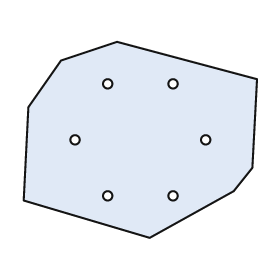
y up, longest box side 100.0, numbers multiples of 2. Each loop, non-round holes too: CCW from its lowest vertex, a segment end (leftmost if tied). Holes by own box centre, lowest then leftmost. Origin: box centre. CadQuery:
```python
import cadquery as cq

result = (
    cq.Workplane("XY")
    .moveTo(4.0, -42.0)
    .lineTo(40.0, -22.0)
    .lineTo(48.0, -12.0)
    .lineTo(50.0, 26.0)
    .lineTo(-10.0, 42.0)
    .lineTo(-34.0, 34.0)
    .lineTo(-48.0, 14.0)
    .lineTo(-50.0, -26.0)
    .close()
    .moveTo(-14.0, -24.0)
    .circle(2.0)
    .moveTo(14.0, -24.0)
    .circle(2.0)
    .moveTo(-28.0, 0.0)
    .circle(2.0)
    .moveTo(28.0, 0.0)
    .circle(2.0)
    .moveTo(-14.0, 24.0)
    .circle(2.0)
    .moveTo(14.0, 24.0)
    .circle(2.0)
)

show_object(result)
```